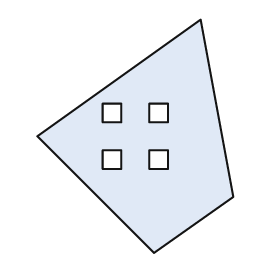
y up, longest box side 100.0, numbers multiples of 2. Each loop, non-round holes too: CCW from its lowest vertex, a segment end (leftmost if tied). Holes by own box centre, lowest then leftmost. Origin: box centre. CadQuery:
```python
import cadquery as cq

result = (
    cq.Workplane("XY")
    .moveTo(8.0, -50.0)
    .lineTo(42.0, -26.0)
    .lineTo(28.0, 50.0)
    .lineTo(-42.0, 0.0)
    .close()
    .moveTo(-14.0, -14.0)
    .lineTo(-6.0, -14.0)
    .lineTo(-6.0, -6.0)
    .lineTo(-14.0, -6.0)
    .close()
    .moveTo(6.0, -14.0)
    .lineTo(14.0, -14.0)
    .lineTo(14.0, -6.0)
    .lineTo(6.0, -6.0)
    .close()
    .moveTo(-14.0, 6.0)
    .lineTo(-6.0, 6.0)
    .lineTo(-6.0, 14.0)
    .lineTo(-14.0, 14.0)
    .close()
    .moveTo(6.0, 6.0)
    .lineTo(14.0, 6.0)
    .lineTo(14.0, 14.0)
    .lineTo(6.0, 14.0)
    .close()
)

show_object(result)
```